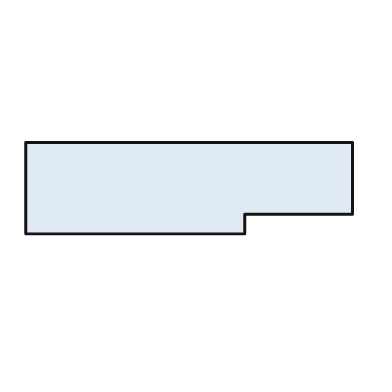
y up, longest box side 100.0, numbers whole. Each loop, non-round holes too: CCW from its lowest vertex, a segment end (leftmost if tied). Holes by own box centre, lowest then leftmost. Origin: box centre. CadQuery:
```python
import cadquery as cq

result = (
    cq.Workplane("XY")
    .moveTo(-50.0, -14.0)
    .lineTo(17.0, -14.0)
    .lineTo(17.0, -8.0)
    .lineTo(50.0, -8.0)
    .lineTo(50.0, 14.0)
    .lineTo(-50.0, 14.0)
    .close()
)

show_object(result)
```